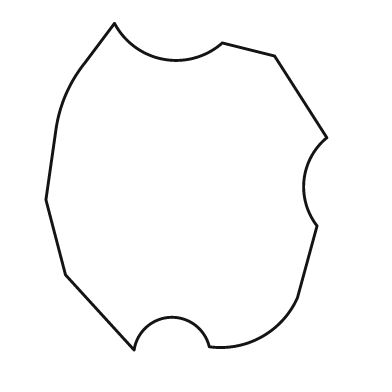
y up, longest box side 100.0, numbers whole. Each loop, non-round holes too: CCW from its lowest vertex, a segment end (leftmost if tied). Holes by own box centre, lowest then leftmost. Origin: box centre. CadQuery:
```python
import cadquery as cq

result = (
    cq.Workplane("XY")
    .moveTo(-16.0, -50.0)
    .threePointArc((-5.0, -40.0), (7.0, -49.0))
    .threePointArc((23.0, -46.0), (34.0, -34.0))
    .lineTo(40.0, -12.0)
    .threePointArc((36.0, 2.0), (43.0, 15.0))
    .lineTo(27.0, 40.0)
    .lineTo(11.0, 44.0)
    .threePointArc((-7.0, 39.0), (-22.0, 50.0))
    .lineTo(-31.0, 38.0)
    .threePointArc((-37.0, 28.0), (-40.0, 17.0))
    .lineTo(-43.0, -4.0)
    .lineTo(-37.0, -27.0)
    .close()
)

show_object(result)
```